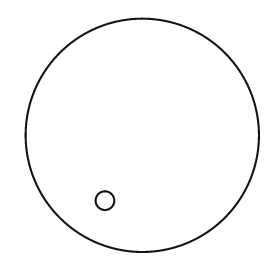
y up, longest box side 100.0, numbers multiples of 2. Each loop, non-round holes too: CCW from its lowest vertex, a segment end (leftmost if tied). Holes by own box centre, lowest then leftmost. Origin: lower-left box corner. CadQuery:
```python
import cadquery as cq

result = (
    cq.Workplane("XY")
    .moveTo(50.0, 50.0)
    .circle(50.0)
    .moveTo(34.0, 22.0)
    .circle(4.0)
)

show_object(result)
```